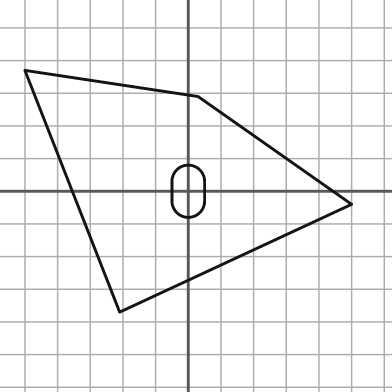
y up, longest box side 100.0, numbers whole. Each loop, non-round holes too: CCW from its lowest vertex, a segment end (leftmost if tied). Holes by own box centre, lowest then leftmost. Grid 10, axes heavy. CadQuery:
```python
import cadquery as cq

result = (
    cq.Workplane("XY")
    .moveTo(-21.0, -37.0)
    .lineTo(50.0, -4.0)
    .lineTo(3.0, 29.0)
    .lineTo(-50.0, 37.0)
    .close()
    .moveTo(-5.0, -3.0)
    .threePointArc((0.0, -8.0), (5.0, -3.0))
    .lineTo(5.0, 3.0)
    .threePointArc((0.0, 8.0), (-5.0, 3.0))
    .close()
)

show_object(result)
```